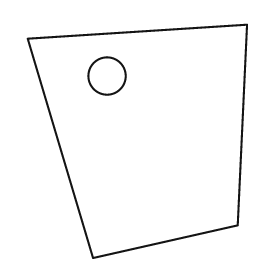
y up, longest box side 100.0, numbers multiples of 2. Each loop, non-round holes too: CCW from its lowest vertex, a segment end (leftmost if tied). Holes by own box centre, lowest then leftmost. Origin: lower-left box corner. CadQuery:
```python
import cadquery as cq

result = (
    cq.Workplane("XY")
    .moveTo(28.0, 0.0)
    .lineTo(90.0, 14.0)
    .lineTo(94.0, 100.0)
    .lineTo(0.0, 94.0)
    .close()
    .moveTo(34.0, 78.0)
    .circle(8.0)
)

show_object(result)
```